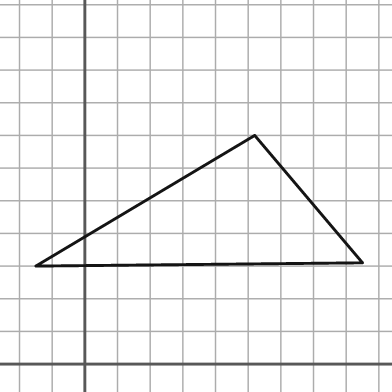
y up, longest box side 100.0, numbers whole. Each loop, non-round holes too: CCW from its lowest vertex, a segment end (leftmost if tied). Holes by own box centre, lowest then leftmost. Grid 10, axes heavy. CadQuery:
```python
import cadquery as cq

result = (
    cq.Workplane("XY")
    .moveTo(-15.0, 30.0)
    .lineTo(85.0, 31.0)
    .lineTo(52.0, 70.0)
    .close()
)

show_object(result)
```